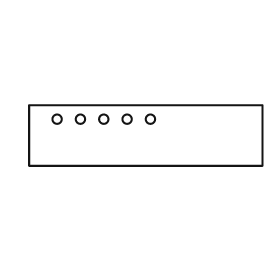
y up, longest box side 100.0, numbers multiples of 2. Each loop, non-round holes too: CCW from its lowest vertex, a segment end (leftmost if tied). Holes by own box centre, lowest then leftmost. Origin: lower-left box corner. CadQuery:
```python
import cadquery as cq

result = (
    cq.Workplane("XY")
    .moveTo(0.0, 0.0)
    .lineTo(100.0, 0.0)
    .lineTo(100.0, 26.0)
    .lineTo(0.0, 26.0)
    .close()
    .moveTo(12.0, 20.0)
    .circle(2.0)
    .moveTo(22.0, 20.0)
    .circle(2.0)
    .moveTo(32.0, 20.0)
    .circle(2.0)
    .moveTo(42.0, 20.0)
    .circle(2.0)
    .moveTo(52.0, 20.0)
    .circle(2.0)
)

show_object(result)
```